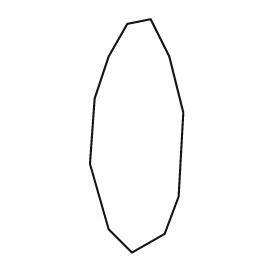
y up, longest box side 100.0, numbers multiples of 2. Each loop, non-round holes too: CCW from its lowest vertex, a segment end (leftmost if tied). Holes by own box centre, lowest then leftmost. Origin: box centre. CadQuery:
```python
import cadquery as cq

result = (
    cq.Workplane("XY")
    .moveTo(-2.0, -50.0)
    .lineTo(12.0, -42.0)
    .lineTo(18.0, -26.0)
    .lineTo(20.0, 10.0)
    .lineTo(14.0, 34.0)
    .lineTo(6.0, 50.0)
    .lineTo(-4.0, 48.0)
    .lineTo(-12.0, 34.0)
    .lineTo(-18.0, 16.0)
    .lineTo(-20.0, -12.0)
    .lineTo(-12.0, -40.0)
    .close()
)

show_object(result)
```